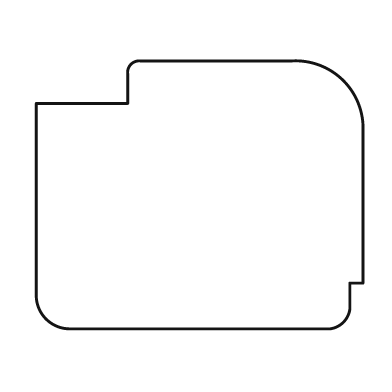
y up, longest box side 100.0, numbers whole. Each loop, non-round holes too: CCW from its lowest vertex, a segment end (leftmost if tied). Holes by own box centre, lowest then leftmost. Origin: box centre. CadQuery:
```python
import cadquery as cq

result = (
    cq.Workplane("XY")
    .moveTo(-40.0, -41.0)
    .lineTo(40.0, -41.0)
    .threePointArc((44.0, -39.0), (46.0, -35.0))
    .lineTo(46.0, -27.0)
    .lineTo(50.0, -27.0)
    .lineTo(50.0, 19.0)
    .threePointArc((44.0, 35.0), (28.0, 41.0))
    .lineTo(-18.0, 41.0)
    .threePointArc((-21.0, 40.0), (-22.0, 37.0))
    .lineTo(-22.0, 28.0)
    .lineTo(-50.0, 28.0)
    .lineTo(-50.0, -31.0)
    .threePointArc((-47.0, -38.0), (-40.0, -41.0))
    .close()
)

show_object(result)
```